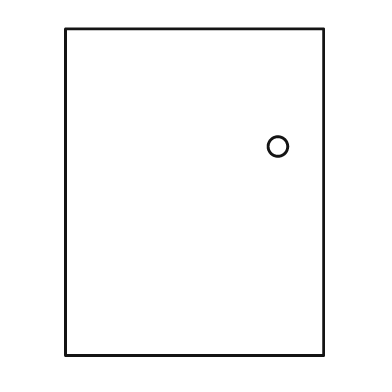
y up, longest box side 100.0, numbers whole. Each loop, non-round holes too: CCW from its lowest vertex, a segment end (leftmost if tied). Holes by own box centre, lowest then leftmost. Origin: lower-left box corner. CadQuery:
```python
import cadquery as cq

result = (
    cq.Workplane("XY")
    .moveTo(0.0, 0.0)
    .lineTo(79.0, 0.0)
    .lineTo(79.0, 100.0)
    .lineTo(0.0, 100.0)
    .close()
    .moveTo(65.0, 64.0)
    .circle(3.0)
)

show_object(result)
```